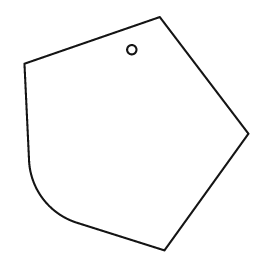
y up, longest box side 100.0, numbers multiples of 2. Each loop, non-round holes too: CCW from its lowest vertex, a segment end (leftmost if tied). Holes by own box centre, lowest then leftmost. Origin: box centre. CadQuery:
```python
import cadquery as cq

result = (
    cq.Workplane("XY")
    .moveTo(12.0, -50.0)
    .lineTo(48.0, 0.0)
    .lineTo(10.0, 50.0)
    .lineTo(-48.0, 30.0)
    .lineTo(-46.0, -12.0)
    .threePointArc((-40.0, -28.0), (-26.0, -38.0))
    .close()
    .moveTo(-2.0, 36.0)
    .circle(2.0)
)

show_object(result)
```